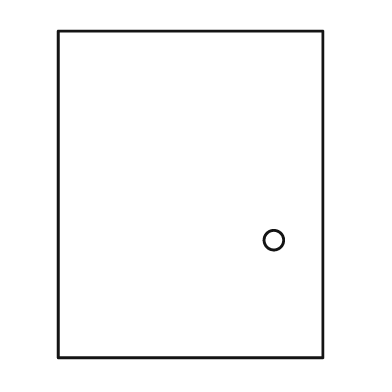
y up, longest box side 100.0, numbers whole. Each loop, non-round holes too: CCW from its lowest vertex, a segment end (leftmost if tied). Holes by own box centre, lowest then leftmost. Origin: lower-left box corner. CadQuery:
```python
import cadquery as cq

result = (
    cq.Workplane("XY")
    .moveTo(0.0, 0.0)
    .lineTo(81.0, 0.0)
    .lineTo(81.0, 100.0)
    .lineTo(0.0, 100.0)
    .close()
    .moveTo(66.0, 36.0)
    .circle(3.0)
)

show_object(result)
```